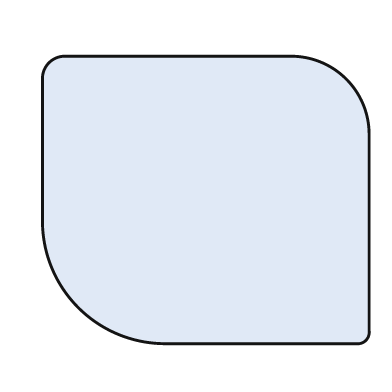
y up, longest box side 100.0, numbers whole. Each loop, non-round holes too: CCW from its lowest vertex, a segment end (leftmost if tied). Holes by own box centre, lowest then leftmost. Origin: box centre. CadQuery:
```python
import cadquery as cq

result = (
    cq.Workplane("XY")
    .moveTo(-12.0, -44.0)
    .lineTo(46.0, -44.0)
    .threePointArc((49.0, -43.0), (50.0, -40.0))
    .lineTo(50.0, 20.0)
    .threePointArc((43.0, 37.0), (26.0, 44.0))
    .lineTo(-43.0, 44.0)
    .threePointArc((-48.0, 42.0), (-50.0, 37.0))
    .lineTo(-50.0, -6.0)
    .threePointArc((-39.0, -33.0), (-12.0, -44.0))
    .close()
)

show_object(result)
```